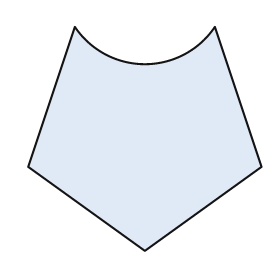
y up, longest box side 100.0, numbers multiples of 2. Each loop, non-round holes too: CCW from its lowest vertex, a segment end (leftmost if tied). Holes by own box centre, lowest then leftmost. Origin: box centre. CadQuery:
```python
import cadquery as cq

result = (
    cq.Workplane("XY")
    .moveTo(0.0, -48.0)
    .lineTo(50.0, -12.0)
    .lineTo(30.0, 48.0)
    .threePointArc((0.0, 32.0), (-30.0, 48.0))
    .lineTo(-50.0, -12.0)
    .close()
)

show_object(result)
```